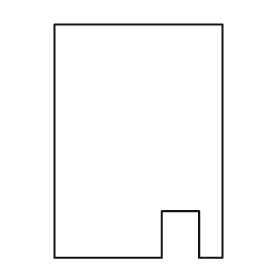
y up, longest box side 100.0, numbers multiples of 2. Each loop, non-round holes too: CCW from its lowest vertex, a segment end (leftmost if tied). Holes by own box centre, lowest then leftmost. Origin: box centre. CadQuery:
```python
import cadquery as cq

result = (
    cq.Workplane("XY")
    .moveTo(-36.0, -50.0)
    .lineTo(10.0, -50.0)
    .lineTo(10.0, -30.0)
    .lineTo(26.0, -30.0)
    .lineTo(26.0, -50.0)
    .lineTo(36.0, -50.0)
    .lineTo(36.0, 50.0)
    .lineTo(-36.0, 50.0)
    .close()
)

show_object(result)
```